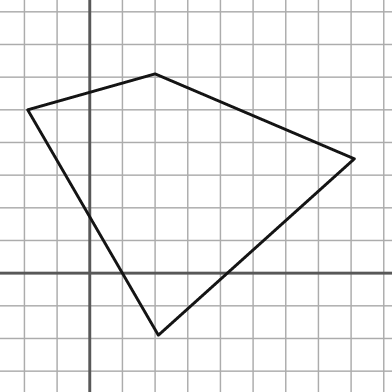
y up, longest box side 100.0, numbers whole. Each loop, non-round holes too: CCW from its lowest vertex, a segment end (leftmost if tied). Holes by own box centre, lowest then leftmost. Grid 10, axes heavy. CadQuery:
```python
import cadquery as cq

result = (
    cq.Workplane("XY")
    .moveTo(21.0, -19.0)
    .lineTo(81.0, 35.0)
    .lineTo(20.0, 61.0)
    .lineTo(-19.0, 50.0)
    .close()
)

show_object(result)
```